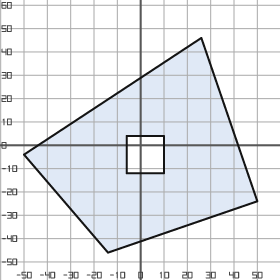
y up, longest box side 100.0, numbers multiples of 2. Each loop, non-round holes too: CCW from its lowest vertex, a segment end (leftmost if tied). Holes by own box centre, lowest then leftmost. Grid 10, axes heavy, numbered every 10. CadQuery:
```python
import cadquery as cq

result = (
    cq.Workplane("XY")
    .moveTo(-14.0, -46.0)
    .lineTo(50.0, -24.0)
    .lineTo(26.0, 46.0)
    .lineTo(-50.0, -4.0)
    .close()
    .moveTo(-6.0, -12.0)
    .lineTo(10.0, -12.0)
    .lineTo(10.0, 4.0)
    .lineTo(-6.0, 4.0)
    .close()
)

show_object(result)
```